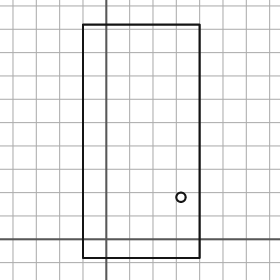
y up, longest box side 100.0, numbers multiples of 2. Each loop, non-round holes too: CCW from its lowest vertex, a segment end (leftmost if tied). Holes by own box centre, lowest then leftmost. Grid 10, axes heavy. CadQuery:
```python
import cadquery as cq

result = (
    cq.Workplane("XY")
    .moveTo(-10.0, -8.0)
    .lineTo(40.0, -8.0)
    .lineTo(40.0, 92.0)
    .lineTo(-10.0, 92.0)
    .close()
    .moveTo(32.0, 18.0)
    .circle(2.0)
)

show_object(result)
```